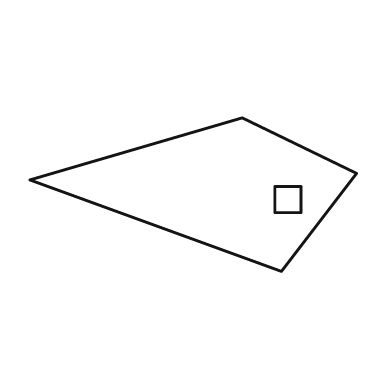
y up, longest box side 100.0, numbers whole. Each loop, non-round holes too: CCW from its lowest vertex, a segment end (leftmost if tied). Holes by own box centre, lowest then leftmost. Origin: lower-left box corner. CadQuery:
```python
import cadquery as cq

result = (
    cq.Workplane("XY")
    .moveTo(77.0, 0.0)
    .lineTo(100.0, 30.0)
    .lineTo(65.0, 47.0)
    .lineTo(0.0, 28.0)
    .close()
    .moveTo(75.0, 18.0)
    .lineTo(83.0, 18.0)
    .lineTo(83.0, 26.0)
    .lineTo(75.0, 26.0)
    .close()
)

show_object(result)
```